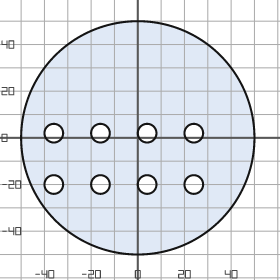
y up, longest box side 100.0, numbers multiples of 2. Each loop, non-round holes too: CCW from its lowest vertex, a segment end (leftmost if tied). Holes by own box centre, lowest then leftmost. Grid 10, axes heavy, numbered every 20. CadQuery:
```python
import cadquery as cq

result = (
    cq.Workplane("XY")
    .moveTo(0.0, 0.0)
    .circle(50.0)
    .moveTo(-36.0, -20.0)
    .circle(4.0)
    .moveTo(-16.0, -20.0)
    .circle(4.0)
    .moveTo(4.0, -20.0)
    .circle(4.0)
    .moveTo(24.0, -20.0)
    .circle(4.0)
    .moveTo(-36.0, 2.0)
    .circle(4.0)
    .moveTo(-16.0, 2.0)
    .circle(4.0)
    .moveTo(4.0, 2.0)
    .circle(4.0)
    .moveTo(24.0, 2.0)
    .circle(4.0)
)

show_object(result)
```